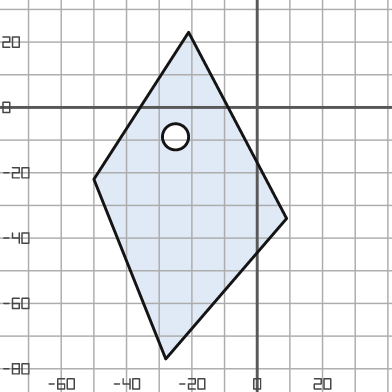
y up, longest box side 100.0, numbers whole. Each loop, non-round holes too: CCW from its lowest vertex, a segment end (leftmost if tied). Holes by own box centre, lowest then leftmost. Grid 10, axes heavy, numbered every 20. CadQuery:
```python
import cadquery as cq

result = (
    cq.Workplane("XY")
    .moveTo(-28.0, -77.0)
    .lineTo(9.0, -34.0)
    .lineTo(-21.0, 23.0)
    .lineTo(-50.0, -22.0)
    .close()
    .moveTo(-25.0, -9.0)
    .circle(4.0)
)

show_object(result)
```